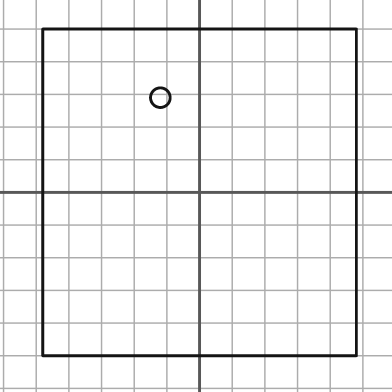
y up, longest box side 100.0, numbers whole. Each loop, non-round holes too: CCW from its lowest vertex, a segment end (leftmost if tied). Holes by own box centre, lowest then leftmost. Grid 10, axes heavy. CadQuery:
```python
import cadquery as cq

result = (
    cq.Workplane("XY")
    .moveTo(-48.0, -50.0)
    .lineTo(48.0, -50.0)
    .lineTo(48.0, 50.0)
    .lineTo(-48.0, 50.0)
    .close()
    .moveTo(-12.0, 29.0)
    .circle(3.0)
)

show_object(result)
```